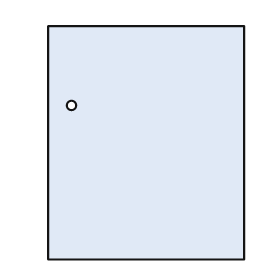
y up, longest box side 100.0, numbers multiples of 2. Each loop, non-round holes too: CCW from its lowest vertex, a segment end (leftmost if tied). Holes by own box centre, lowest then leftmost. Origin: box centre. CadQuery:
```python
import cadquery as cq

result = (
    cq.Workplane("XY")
    .moveTo(-42.0, -50.0)
    .lineTo(42.0, -50.0)
    .lineTo(42.0, 50.0)
    .lineTo(-42.0, 50.0)
    .close()
    .moveTo(-32.0, 16.0)
    .circle(2.0)
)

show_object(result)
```